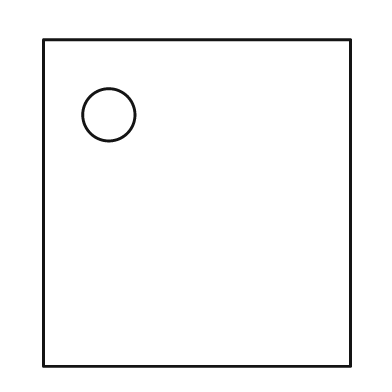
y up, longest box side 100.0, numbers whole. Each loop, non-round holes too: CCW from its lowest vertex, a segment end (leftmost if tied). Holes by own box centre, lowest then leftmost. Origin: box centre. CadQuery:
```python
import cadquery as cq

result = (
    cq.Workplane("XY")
    .moveTo(-47.0, -50.0)
    .lineTo(47.0, -50.0)
    .lineTo(47.0, 50.0)
    .lineTo(-47.0, 50.0)
    .close()
    .moveTo(-27.0, 27.0)
    .circle(8.0)
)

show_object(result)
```